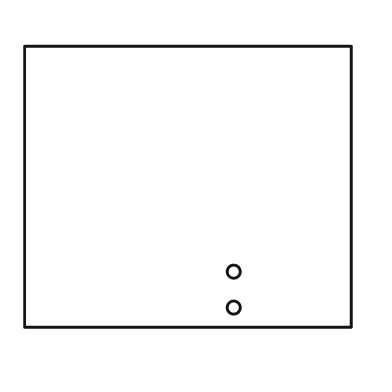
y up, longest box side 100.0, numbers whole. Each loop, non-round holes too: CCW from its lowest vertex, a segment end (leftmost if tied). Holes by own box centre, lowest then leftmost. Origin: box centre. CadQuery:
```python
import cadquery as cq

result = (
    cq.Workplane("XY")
    .moveTo(-50.0, -43.0)
    .lineTo(50.0, -43.0)
    .lineTo(50.0, 43.0)
    .lineTo(-50.0, 43.0)
    .close()
    .moveTo(14.0, -37.0)
    .circle(2.0)
    .moveTo(14.0, -26.0)
    .circle(2.0)
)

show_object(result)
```